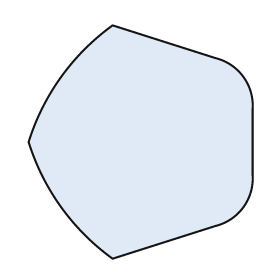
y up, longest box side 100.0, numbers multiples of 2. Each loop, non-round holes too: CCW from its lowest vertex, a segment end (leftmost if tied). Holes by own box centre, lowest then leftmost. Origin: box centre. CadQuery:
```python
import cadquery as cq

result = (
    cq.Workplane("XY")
    .moveTo(-12.0, -50.0)
    .lineTo(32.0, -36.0)
    .threePointArc((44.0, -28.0), (48.0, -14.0))
    .lineTo(48.0, 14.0)
    .threePointArc((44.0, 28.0), (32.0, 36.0))
    .lineTo(-12.0, 50.0)
    .threePointArc((-34.0, 28.0), (-48.0, 0.0))
    .threePointArc((-34.0, -28.0), (-12.0, -50.0))
    .close()
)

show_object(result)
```